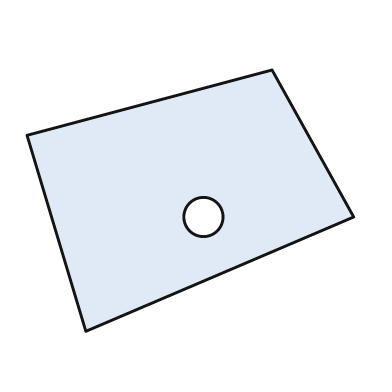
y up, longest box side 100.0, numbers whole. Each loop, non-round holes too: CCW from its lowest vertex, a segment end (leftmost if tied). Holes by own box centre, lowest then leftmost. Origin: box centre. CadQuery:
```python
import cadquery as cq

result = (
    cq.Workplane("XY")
    .moveTo(-32.0, -40.0)
    .lineTo(50.0, -5.0)
    .lineTo(25.0, 40.0)
    .lineTo(-50.0, 20.0)
    .close()
    .moveTo(4.0, -5.0)
    .circle(6.0)
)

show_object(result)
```